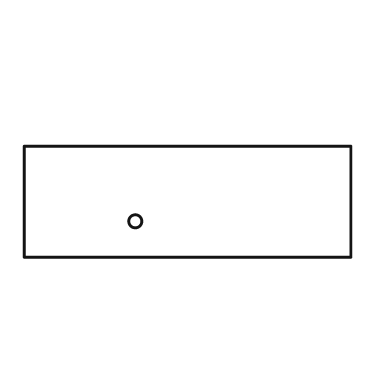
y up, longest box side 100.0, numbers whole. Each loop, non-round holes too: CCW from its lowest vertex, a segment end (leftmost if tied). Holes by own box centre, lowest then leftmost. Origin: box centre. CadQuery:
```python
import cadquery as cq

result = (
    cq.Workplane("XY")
    .moveTo(-50.0, -17.0)
    .lineTo(50.0, -17.0)
    .lineTo(50.0, 17.0)
    .lineTo(-50.0, 17.0)
    .close()
    .moveTo(-16.0, -6.0)
    .circle(2.0)
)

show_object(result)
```